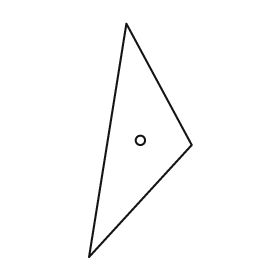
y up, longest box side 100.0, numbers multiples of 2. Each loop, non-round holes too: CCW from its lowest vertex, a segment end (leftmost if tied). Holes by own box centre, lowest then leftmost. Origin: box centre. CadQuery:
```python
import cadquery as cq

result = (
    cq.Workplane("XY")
    .moveTo(-22.0, -50.0)
    .lineTo(22.0, -2.0)
    .lineTo(-6.0, 50.0)
    .close()
    .moveTo(0.0, 0.0)
    .circle(2.0)
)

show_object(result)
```